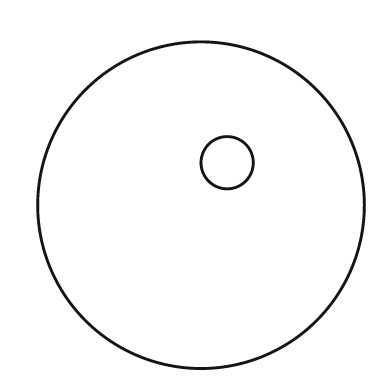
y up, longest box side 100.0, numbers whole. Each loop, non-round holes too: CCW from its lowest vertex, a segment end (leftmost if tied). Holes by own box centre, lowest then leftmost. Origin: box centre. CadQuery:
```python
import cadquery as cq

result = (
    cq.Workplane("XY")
    .moveTo(0.0, 0.0)
    .circle(50.0)
    .moveTo(8.0, 13.0)
    .circle(8.0)
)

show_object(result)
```